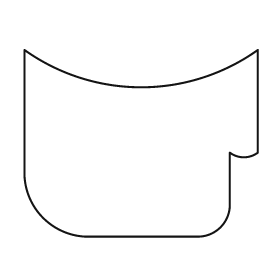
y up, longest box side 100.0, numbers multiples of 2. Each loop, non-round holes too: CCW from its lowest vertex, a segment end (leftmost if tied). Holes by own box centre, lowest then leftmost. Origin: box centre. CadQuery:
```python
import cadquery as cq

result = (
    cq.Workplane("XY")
    .moveTo(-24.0, -40.0)
    .lineTo(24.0, -40.0)
    .threePointArc((34.0, -36.0), (38.0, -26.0))
    .lineTo(38.0, -4.0)
    .threePointArc((44.0, -6.0), (50.0, -4.0))
    .lineTo(50.0, 40.0)
    .threePointArc((0.0, 24.0), (-50.0, 40.0))
    .lineTo(-50.0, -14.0)
    .threePointArc((-42.0, -32.0), (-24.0, -40.0))
    .close()
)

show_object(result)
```